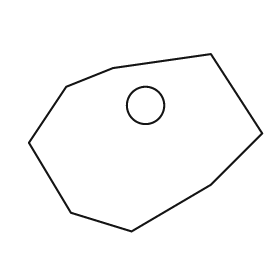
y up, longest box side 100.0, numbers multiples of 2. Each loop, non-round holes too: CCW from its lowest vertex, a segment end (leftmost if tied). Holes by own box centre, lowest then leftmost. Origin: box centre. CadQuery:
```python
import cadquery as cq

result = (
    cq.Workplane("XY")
    .moveTo(-6.0, -38.0)
    .lineTo(28.0, -18.0)
    .lineTo(50.0, 4.0)
    .lineTo(28.0, 38.0)
    .lineTo(-14.0, 32.0)
    .lineTo(-34.0, 24.0)
    .lineTo(-50.0, 0.0)
    .lineTo(-32.0, -30.0)
    .close()
    .moveTo(0.0, 16.0)
    .circle(8.0)
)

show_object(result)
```